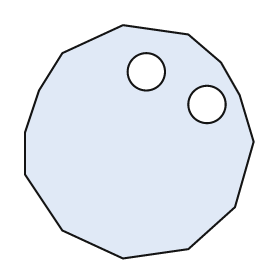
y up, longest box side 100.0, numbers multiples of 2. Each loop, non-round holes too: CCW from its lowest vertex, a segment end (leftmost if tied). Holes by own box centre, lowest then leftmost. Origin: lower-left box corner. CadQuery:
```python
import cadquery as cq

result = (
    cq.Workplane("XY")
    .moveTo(42.0, 0.0)
    .lineTo(70.0, 4.0)
    .lineTo(90.0, 22.0)
    .lineTo(98.0, 50.0)
    .lineTo(92.0, 70.0)
    .lineTo(84.0, 84.0)
    .lineTo(70.0, 96.0)
    .lineTo(42.0, 100.0)
    .lineTo(16.0, 88.0)
    .lineTo(6.0, 72.0)
    .lineTo(0.0, 54.0)
    .lineTo(0.0, 36.0)
    .lineTo(16.0, 12.0)
    .close()
    .moveTo(78.0, 66.0)
    .circle(8.0)
    .moveTo(52.0, 80.0)
    .circle(8.0)
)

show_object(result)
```